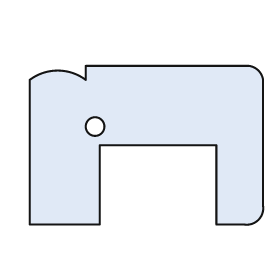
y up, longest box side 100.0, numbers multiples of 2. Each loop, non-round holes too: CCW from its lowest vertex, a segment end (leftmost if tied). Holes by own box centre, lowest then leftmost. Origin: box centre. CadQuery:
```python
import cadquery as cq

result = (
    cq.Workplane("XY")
    .moveTo(-50.0, -34.0)
    .lineTo(-20.0, -34.0)
    .lineTo(-20.0, 0.0)
    .lineTo(30.0, 0.0)
    .lineTo(30.0, -34.0)
    .lineTo(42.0, -34.0)
    .threePointArc((48.0, -32.0), (50.0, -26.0))
    .lineTo(50.0, 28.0)
    .threePointArc((48.0, 32.0), (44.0, 34.0))
    .lineTo(-26.0, 34.0)
    .lineTo(-26.0, 28.0)
    .threePointArc((-38.0, 32.0), (-50.0, 28.0))
    .close()
    .moveTo(-22.0, 8.0)
    .circle(4.0)
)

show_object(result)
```